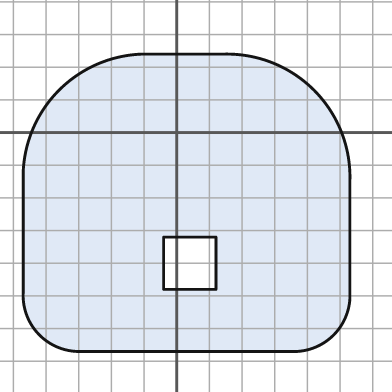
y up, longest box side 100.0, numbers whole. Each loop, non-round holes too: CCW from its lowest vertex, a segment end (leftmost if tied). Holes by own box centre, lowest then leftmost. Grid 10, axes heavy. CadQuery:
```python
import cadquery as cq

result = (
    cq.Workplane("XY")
    .moveTo(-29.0, -67.0)
    .lineTo(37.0, -67.0)
    .threePointArc((48.0, -62.0), (53.0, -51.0))
    .lineTo(53.0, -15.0)
    .threePointArc((42.0, 13.0), (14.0, 24.0))
    .lineTo(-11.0, 24.0)
    .threePointArc((-36.0, 13.0), (-47.0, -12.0))
    .lineTo(-47.0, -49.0)
    .threePointArc((-42.0, -62.0), (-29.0, -67.0))
    .close()
    .moveTo(-4.0, -48.0)
    .lineTo(12.0, -48.0)
    .lineTo(12.0, -32.0)
    .lineTo(-4.0, -32.0)
    .close()
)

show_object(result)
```